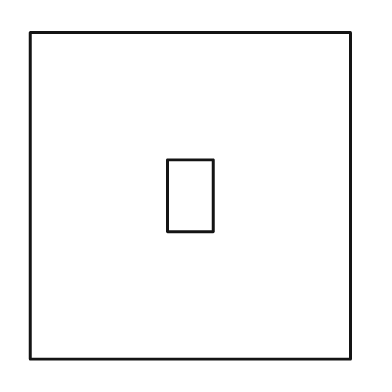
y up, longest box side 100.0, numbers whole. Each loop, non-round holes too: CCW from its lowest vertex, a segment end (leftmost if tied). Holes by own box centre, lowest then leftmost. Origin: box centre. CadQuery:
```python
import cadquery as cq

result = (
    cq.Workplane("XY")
    .moveTo(-49.0, -50.0)
    .lineTo(49.0, -50.0)
    .lineTo(49.0, 50.0)
    .lineTo(-49.0, 50.0)
    .close()
    .moveTo(-7.0, -11.0)
    .lineTo(7.0, -11.0)
    .lineTo(7.0, 11.0)
    .lineTo(-7.0, 11.0)
    .close()
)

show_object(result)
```